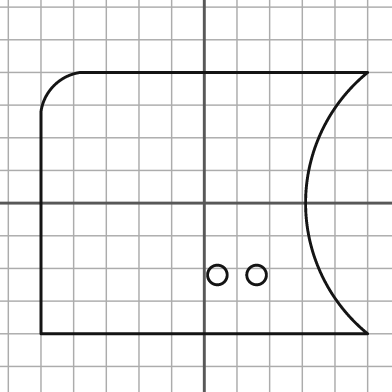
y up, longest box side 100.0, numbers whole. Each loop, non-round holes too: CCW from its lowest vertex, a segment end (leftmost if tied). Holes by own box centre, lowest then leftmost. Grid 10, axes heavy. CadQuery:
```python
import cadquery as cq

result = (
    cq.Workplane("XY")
    .moveTo(-50.0, -40.0)
    .lineTo(50.0, -40.0)
    .threePointArc((31.0, 0.0), (50.0, 40.0))
    .lineTo(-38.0, 40.0)
    .threePointArc((-46.0, 36.0), (-50.0, 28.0))
    .close()
    .moveTo(4.0, -22.0)
    .circle(3.0)
    .moveTo(16.0, -22.0)
    .circle(3.0)
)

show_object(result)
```